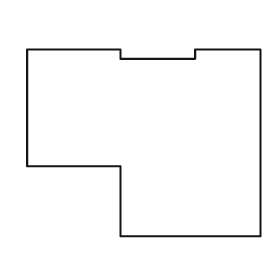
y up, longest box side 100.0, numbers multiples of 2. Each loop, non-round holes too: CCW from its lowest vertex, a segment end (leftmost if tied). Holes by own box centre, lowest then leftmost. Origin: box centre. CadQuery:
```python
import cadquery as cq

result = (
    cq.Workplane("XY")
    .moveTo(-10.0, -40.0)
    .lineTo(50.0, -40.0)
    .lineTo(50.0, 40.0)
    .lineTo(22.0, 40.0)
    .lineTo(22.0, 36.0)
    .lineTo(-10.0, 36.0)
    .lineTo(-10.0, 40.0)
    .lineTo(-50.0, 40.0)
    .lineTo(-50.0, -10.0)
    .lineTo(-10.0, -10.0)
    .close()
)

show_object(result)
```